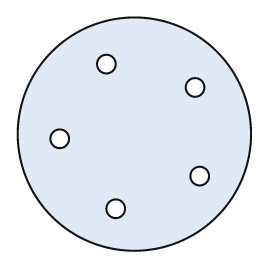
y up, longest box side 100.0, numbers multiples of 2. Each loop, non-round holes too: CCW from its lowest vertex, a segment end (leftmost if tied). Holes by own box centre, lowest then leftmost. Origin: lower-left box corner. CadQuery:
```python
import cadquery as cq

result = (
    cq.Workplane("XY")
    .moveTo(50.0, 50.0)
    .circle(50.0)
    .moveTo(42.0, 18.0)
    .circle(4.0)
    .moveTo(78.0, 32.0)
    .circle(4.0)
    .moveTo(18.0, 48.0)
    .circle(4.0)
    .moveTo(76.0, 70.0)
    .circle(4.0)
    .moveTo(38.0, 80.0)
    .circle(4.0)
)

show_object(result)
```